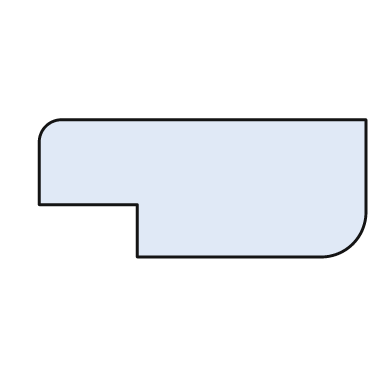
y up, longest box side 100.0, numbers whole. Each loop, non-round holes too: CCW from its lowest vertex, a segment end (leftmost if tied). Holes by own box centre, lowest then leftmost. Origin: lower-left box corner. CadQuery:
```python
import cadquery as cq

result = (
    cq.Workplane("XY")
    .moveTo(30.0, 0.0)
    .lineTo(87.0, 0.0)
    .threePointArc((96.0, 4.0), (100.0, 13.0))
    .lineTo(100.0, 42.0)
    .lineTo(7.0, 42.0)
    .threePointArc((2.0, 40.0), (0.0, 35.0))
    .lineTo(0.0, 16.0)
    .lineTo(30.0, 16.0)
    .close()
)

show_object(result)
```